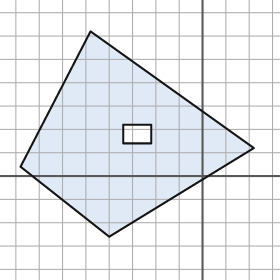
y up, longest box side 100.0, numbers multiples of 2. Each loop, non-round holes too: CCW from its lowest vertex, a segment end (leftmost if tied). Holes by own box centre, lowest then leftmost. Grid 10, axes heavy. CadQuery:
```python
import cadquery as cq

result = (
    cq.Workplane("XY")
    .moveTo(-40.0, -26.0)
    .lineTo(22.0, 12.0)
    .lineTo(-48.0, 62.0)
    .lineTo(-78.0, 4.0)
    .close()
    .moveTo(-34.0, 14.0)
    .lineTo(-22.0, 14.0)
    .lineTo(-22.0, 22.0)
    .lineTo(-34.0, 22.0)
    .close()
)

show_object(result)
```